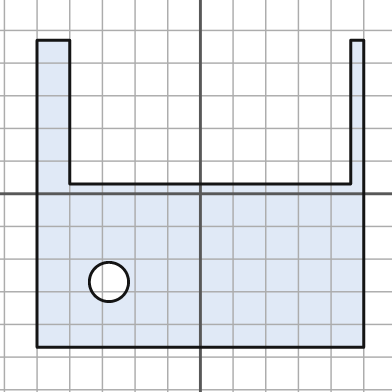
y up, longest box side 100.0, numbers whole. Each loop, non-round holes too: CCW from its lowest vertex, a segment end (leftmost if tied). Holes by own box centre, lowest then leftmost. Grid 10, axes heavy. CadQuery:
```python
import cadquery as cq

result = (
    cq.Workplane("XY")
    .moveTo(-50.0, -47.0)
    .lineTo(50.0, -47.0)
    .lineTo(50.0, 47.0)
    .lineTo(46.0, 47.0)
    .lineTo(46.0, 3.0)
    .lineTo(-40.0, 3.0)
    .lineTo(-40.0, 47.0)
    .lineTo(-50.0, 47.0)
    .close()
    .moveTo(-28.0, -27.0)
    .circle(6.0)
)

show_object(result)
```